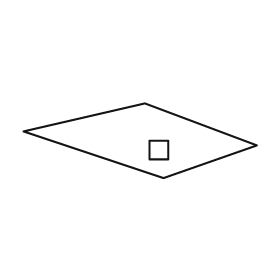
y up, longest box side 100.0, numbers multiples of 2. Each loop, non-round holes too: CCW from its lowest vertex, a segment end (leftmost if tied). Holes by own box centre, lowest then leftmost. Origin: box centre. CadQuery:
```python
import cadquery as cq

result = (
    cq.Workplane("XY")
    .moveTo(10.0, -16.0)
    .lineTo(50.0, -2.0)
    .lineTo(2.0, 16.0)
    .lineTo(-50.0, 4.0)
    .close()
    .moveTo(4.0, -8.0)
    .lineTo(12.0, -8.0)
    .lineTo(12.0, 0.0)
    .lineTo(4.0, 0.0)
    .close()
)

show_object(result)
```